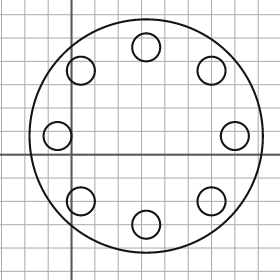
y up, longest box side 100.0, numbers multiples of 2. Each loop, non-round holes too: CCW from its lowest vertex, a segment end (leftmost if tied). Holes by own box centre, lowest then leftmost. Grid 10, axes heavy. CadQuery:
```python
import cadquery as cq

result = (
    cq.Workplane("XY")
    .moveTo(32.0, 8.0)
    .circle(50.0)
    .moveTo(32.0, -30.0)
    .circle(6.0)
    .moveTo(4.0, -20.0)
    .circle(6.0)
    .moveTo(60.0, -20.0)
    .circle(6.0)
    .moveTo(-6.0, 8.0)
    .circle(6.0)
    .moveTo(70.0, 8.0)
    .circle(6.0)
    .moveTo(4.0, 36.0)
    .circle(6.0)
    .moveTo(60.0, 36.0)
    .circle(6.0)
    .moveTo(32.0, 46.0)
    .circle(6.0)
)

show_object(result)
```